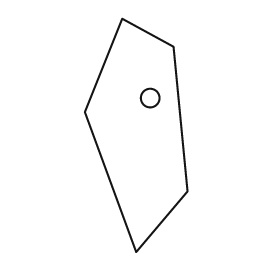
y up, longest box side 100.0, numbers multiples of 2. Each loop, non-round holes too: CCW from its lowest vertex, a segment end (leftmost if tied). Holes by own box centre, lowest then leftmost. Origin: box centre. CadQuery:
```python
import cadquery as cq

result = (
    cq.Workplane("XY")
    .moveTo(0.0, -50.0)
    .lineTo(22.0, -24.0)
    .lineTo(16.0, 38.0)
    .lineTo(-6.0, 50.0)
    .lineTo(-22.0, 10.0)
    .close()
    .moveTo(6.0, 16.0)
    .circle(4.0)
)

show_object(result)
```